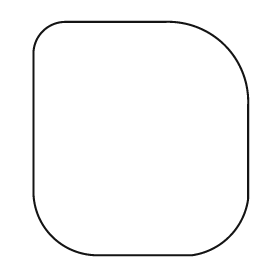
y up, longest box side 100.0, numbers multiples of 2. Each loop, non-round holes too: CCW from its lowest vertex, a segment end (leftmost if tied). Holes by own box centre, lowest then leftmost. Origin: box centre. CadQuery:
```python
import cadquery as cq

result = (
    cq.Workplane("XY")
    .moveTo(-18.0, -50.0)
    .lineTo(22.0, -50.0)
    .threePointArc((38.0, -42.0), (46.0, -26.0))
    .lineTo(46.0, 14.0)
    .threePointArc((36.0, 40.0), (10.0, 50.0))
    .lineTo(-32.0, 50.0)
    .threePointArc((-42.0, 46.0), (-46.0, 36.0))
    .lineTo(-46.0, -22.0)
    .threePointArc((-38.0, -42.0), (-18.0, -50.0))
    .close()
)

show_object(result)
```